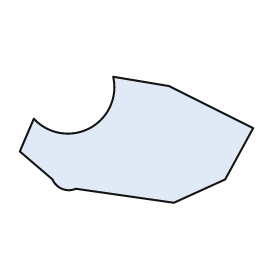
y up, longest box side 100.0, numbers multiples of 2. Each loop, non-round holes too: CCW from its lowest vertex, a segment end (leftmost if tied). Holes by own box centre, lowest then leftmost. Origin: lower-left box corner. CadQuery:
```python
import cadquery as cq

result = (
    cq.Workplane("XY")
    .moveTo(66.0, 0.0)
    .lineTo(88.0, 10.0)
    .lineTo(100.0, 32.0)
    .lineTo(64.0, 50.0)
    .lineTo(40.0, 54.0)
    .threePointArc((30.0, 32.0), (6.0, 36.0))
    .lineTo(0.0, 22.0)
    .lineTo(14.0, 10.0)
    .threePointArc((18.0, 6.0), (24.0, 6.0))
    .close()
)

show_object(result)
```